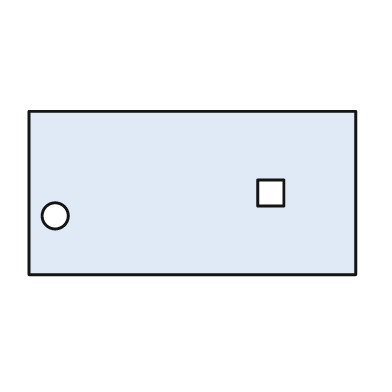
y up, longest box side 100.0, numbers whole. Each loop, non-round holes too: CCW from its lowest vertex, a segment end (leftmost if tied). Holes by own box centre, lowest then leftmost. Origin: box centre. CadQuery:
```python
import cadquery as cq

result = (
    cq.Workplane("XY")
    .moveTo(-50.0, -25.0)
    .lineTo(50.0, -25.0)
    .lineTo(50.0, 25.0)
    .lineTo(-50.0, 25.0)
    .close()
    .moveTo(-42.0, -7.0)
    .circle(4.0)
    .moveTo(20.0, -4.0)
    .lineTo(28.0, -4.0)
    .lineTo(28.0, 4.0)
    .lineTo(20.0, 4.0)
    .close()
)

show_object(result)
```